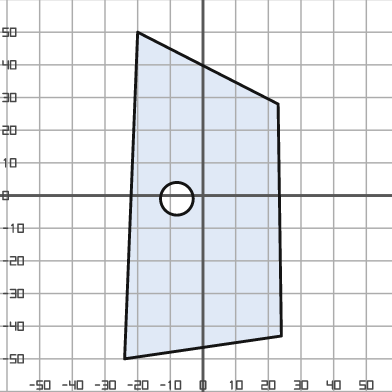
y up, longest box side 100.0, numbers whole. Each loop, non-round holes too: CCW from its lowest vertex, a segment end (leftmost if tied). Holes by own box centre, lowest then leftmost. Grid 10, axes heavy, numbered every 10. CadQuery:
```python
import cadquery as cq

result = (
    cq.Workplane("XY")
    .moveTo(-24.0, -50.0)
    .lineTo(24.0, -43.0)
    .lineTo(23.0, 28.0)
    .lineTo(-20.0, 50.0)
    .close()
    .moveTo(-8.0, -1.0)
    .circle(5.0)
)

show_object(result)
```